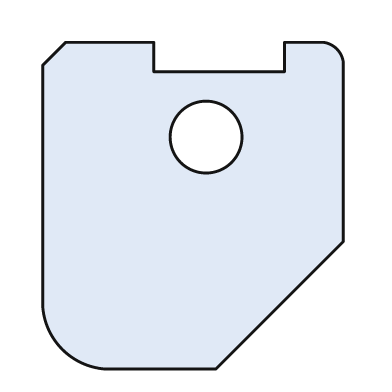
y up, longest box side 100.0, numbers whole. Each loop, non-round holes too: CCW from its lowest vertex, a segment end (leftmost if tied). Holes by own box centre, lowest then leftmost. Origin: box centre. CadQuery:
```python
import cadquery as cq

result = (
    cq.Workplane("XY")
    .moveTo(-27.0, -50.0)
    .lineTo(7.0, -50.0)
    .lineTo(46.0, -11.0)
    .lineTo(46.0, 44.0)
    .threePointArc((44.0, 48.0), (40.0, 50.0))
    .lineTo(28.0, 50.0)
    .lineTo(28.0, 41.0)
    .lineTo(-12.0, 41.0)
    .lineTo(-12.0, 50.0)
    .lineTo(-39.0, 50.0)
    .lineTo(-46.0, 43.0)
    .lineTo(-46.0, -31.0)
    .threePointArc((-40.0, -44.0), (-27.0, -50.0))
    .close()
    .moveTo(4.0, 21.0)
    .circle(11.0)
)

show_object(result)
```